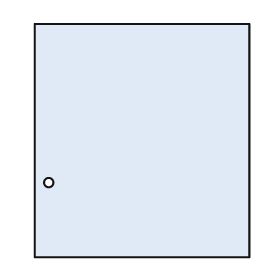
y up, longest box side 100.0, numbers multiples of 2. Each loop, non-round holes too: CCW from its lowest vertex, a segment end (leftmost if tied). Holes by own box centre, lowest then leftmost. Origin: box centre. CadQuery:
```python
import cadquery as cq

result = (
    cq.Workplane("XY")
    .moveTo(-46.0, -50.0)
    .lineTo(46.0, -50.0)
    .lineTo(46.0, 50.0)
    .lineTo(-46.0, 50.0)
    .close()
    .moveTo(-40.0, -18.0)
    .circle(2.0)
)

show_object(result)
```